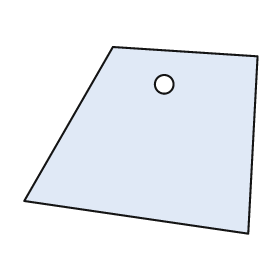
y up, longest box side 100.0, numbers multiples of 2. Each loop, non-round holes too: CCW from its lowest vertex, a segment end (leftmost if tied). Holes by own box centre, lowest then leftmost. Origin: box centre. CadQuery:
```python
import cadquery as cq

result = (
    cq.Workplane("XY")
    .moveTo(46.0, -40.0)
    .lineTo(50.0, 36.0)
    .lineTo(-12.0, 40.0)
    .lineTo(-50.0, -26.0)
    .close()
    .moveTo(10.0, 24.0)
    .circle(4.0)
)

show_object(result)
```